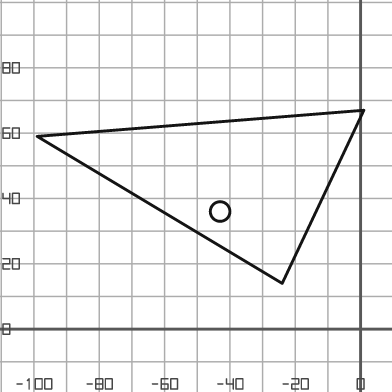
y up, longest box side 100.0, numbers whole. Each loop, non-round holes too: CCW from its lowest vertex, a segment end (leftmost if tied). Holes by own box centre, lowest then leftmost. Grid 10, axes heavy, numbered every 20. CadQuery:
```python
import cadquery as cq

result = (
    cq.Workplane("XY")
    .moveTo(-24.0, 14.0)
    .lineTo(1.0, 67.0)
    .lineTo(-99.0, 59.0)
    .close()
    .moveTo(-43.0, 36.0)
    .circle(3.0)
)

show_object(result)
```